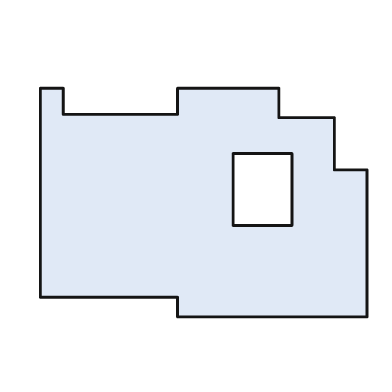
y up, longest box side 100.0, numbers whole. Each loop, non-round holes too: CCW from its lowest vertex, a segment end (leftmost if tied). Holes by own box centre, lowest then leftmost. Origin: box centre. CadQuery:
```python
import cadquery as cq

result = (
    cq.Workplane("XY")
    .moveTo(-8.0, -35.0)
    .lineTo(50.0, -35.0)
    .lineTo(50.0, 10.0)
    .lineTo(40.0, 10.0)
    .lineTo(40.0, 26.0)
    .lineTo(23.0, 26.0)
    .lineTo(23.0, 35.0)
    .lineTo(-8.0, 35.0)
    .lineTo(-8.0, 27.0)
    .lineTo(-43.0, 27.0)
    .lineTo(-43.0, 35.0)
    .lineTo(-50.0, 35.0)
    .lineTo(-50.0, -29.0)
    .lineTo(-8.0, -29.0)
    .close()
    .moveTo(9.0, -7.0)
    .lineTo(27.0, -7.0)
    .lineTo(27.0, 15.0)
    .lineTo(9.0, 15.0)
    .close()
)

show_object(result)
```